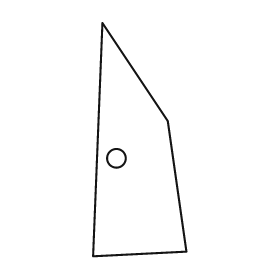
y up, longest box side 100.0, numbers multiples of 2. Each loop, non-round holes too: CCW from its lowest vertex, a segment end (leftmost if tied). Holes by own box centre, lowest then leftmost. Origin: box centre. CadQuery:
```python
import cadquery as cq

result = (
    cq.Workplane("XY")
    .moveTo(-20.0, -50.0)
    .lineTo(20.0, -48.0)
    .lineTo(12.0, 8.0)
    .lineTo(-16.0, 50.0)
    .close()
    .moveTo(-10.0, -8.0)
    .circle(4.0)
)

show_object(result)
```